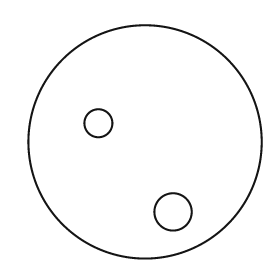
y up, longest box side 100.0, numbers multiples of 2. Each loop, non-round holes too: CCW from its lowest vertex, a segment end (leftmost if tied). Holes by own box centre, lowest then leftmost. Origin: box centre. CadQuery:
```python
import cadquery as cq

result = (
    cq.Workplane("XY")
    .moveTo(0.0, 0.0)
    .circle(50.0)
    .moveTo(12.0, -30.0)
    .circle(8.0)
    .moveTo(-20.0, 8.0)
    .circle(6.0)
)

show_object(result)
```